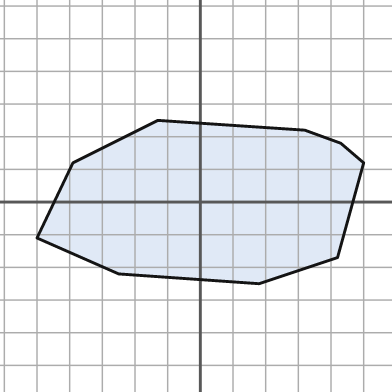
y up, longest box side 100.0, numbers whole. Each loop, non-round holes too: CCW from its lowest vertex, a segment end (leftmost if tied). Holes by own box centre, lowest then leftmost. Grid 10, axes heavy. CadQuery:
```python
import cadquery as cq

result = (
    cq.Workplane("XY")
    .moveTo(18.0, -25.0)
    .lineTo(42.0, -17.0)
    .lineTo(50.0, 12.0)
    .lineTo(43.0, 18.0)
    .lineTo(32.0, 22.0)
    .lineTo(-13.0, 25.0)
    .lineTo(-39.0, 12.0)
    .lineTo(-50.0, -11.0)
    .lineTo(-25.0, -22.0)
    .close()
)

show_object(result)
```